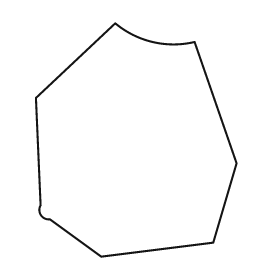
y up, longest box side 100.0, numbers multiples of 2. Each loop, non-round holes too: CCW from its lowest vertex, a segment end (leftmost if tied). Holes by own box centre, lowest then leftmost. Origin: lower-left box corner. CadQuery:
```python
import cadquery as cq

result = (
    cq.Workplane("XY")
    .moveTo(28.0, 0.0)
    .lineTo(76.0, 6.0)
    .lineTo(86.0, 40.0)
    .lineTo(68.0, 92.0)
    .threePointArc((50.0, 92.0), (34.0, 100.0))
    .lineTo(0.0, 68.0)
    .lineTo(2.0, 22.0)
    .threePointArc((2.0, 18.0), (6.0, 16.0))
    .close()
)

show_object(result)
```